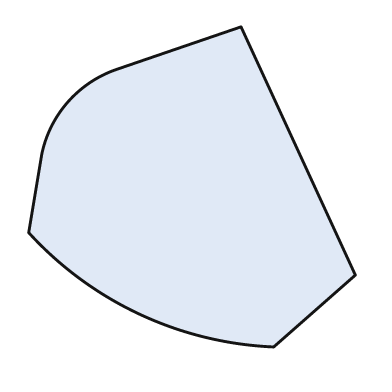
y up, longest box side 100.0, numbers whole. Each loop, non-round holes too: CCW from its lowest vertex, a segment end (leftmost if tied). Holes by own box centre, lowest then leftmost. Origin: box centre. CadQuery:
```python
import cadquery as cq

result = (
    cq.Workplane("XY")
    .moveTo(25.0, -49.0)
    .lineTo(50.0, -27.0)
    .lineTo(15.0, 49.0)
    .lineTo(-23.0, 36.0)
    .threePointArc((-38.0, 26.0), (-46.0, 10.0))
    .lineTo(-50.0, -14.0)
    .threePointArc((-16.0, -39.0), (25.0, -49.0))
    .close()
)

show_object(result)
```